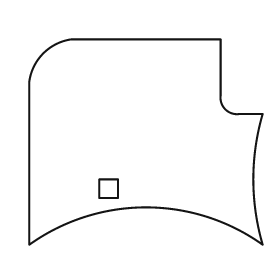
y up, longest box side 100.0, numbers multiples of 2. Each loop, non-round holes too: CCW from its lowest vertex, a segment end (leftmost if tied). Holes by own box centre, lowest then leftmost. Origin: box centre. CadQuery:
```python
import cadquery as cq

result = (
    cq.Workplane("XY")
    .moveTo(-50.0, -44.0)
    .threePointArc((0.0, -28.0), (50.0, -44.0))
    .threePointArc((46.0, -16.0), (50.0, 12.0))
    .lineTo(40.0, 12.0)
    .threePointArc((34.0, 14.0), (32.0, 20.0))
    .lineTo(32.0, 44.0)
    .lineTo(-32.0, 44.0)
    .threePointArc((-44.0, 38.0), (-50.0, 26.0))
    .close()
    .moveTo(-20.0, -24.0)
    .lineTo(-12.0, -24.0)
    .lineTo(-12.0, -16.0)
    .lineTo(-20.0, -16.0)
    .close()
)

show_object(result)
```